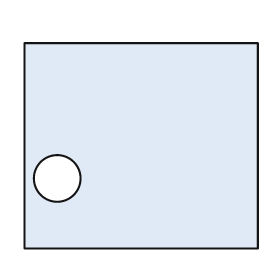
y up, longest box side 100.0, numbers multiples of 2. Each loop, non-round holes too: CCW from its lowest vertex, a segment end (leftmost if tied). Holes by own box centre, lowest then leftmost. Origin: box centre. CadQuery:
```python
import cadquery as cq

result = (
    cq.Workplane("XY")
    .moveTo(-50.0, -44.0)
    .lineTo(50.0, -44.0)
    .lineTo(50.0, 44.0)
    .lineTo(-50.0, 44.0)
    .close()
    .moveTo(-36.0, -14.0)
    .circle(10.0)
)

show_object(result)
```